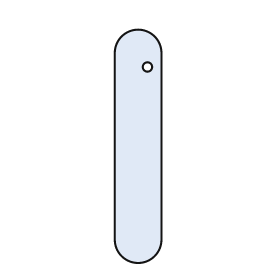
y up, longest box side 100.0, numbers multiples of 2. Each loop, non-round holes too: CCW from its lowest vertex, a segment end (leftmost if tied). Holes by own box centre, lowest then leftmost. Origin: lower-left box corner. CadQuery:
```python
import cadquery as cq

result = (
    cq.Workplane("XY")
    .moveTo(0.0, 10.0)
    .threePointArc((10.0, 0.0), (20.0, 10.0))
    .lineTo(20.0, 90.0)
    .threePointArc((10.0, 100.0), (0.0, 90.0))
    .close()
    .moveTo(14.0, 84.0)
    .circle(2.0)
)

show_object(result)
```